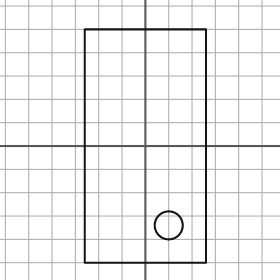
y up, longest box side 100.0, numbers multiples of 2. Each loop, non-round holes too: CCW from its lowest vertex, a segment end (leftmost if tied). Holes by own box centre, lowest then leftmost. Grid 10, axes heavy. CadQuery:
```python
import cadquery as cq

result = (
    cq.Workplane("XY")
    .moveTo(-26.0, -50.0)
    .lineTo(26.0, -50.0)
    .lineTo(26.0, 50.0)
    .lineTo(-26.0, 50.0)
    .close()
    .moveTo(10.0, -34.0)
    .circle(6.0)
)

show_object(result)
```